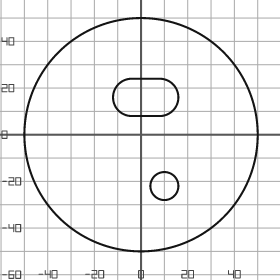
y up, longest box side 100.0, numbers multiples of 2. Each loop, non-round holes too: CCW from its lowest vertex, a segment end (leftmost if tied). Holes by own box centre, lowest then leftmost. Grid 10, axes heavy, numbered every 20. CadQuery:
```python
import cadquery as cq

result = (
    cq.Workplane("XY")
    .moveTo(0.0, 0.0)
    .circle(50.0)
    .moveTo(10.0, -22.0)
    .circle(6.0)
    .moveTo(-4.0, 8.0)
    .lineTo(8.0, 8.0)
    .threePointArc((16.0, 16.0), (8.0, 24.0))
    .lineTo(-4.0, 24.0)
    .threePointArc((-12.0, 16.0), (-4.0, 8.0))
    .close()
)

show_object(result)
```